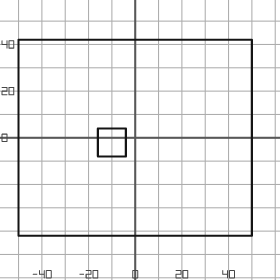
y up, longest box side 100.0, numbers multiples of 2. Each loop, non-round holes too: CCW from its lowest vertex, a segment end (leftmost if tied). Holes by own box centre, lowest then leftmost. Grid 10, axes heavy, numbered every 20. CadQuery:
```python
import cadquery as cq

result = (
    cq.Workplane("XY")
    .moveTo(-50.0, -42.0)
    .lineTo(50.0, -42.0)
    .lineTo(50.0, 42.0)
    .lineTo(-50.0, 42.0)
    .close()
    .moveTo(-16.0, -8.0)
    .lineTo(-4.0, -8.0)
    .lineTo(-4.0, 4.0)
    .lineTo(-16.0, 4.0)
    .close()
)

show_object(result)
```